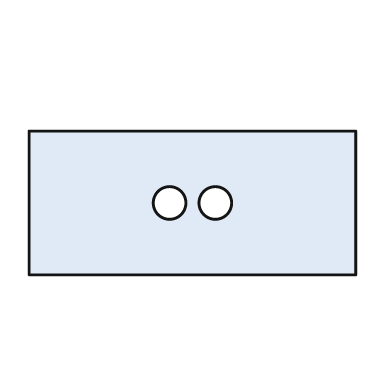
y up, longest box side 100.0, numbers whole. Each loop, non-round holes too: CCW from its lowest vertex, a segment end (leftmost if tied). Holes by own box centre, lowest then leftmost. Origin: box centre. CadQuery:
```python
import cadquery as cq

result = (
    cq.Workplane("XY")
    .moveTo(-50.0, -22.0)
    .lineTo(50.0, -22.0)
    .lineTo(50.0, 22.0)
    .lineTo(-50.0, 22.0)
    .close()
    .moveTo(-7.0, 0.0)
    .circle(5.0)
    .moveTo(7.0, 0.0)
    .circle(5.0)
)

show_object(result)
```